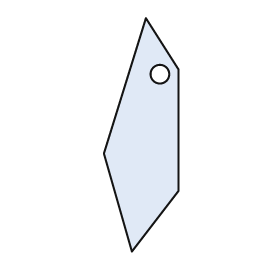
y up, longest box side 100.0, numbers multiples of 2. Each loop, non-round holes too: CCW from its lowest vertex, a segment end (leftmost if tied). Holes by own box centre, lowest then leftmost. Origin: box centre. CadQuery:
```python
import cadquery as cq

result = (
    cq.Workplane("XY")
    .moveTo(-4.0, -50.0)
    .lineTo(16.0, -24.0)
    .lineTo(16.0, 28.0)
    .lineTo(2.0, 50.0)
    .lineTo(-16.0, -8.0)
    .close()
    .moveTo(8.0, 26.0)
    .circle(4.0)
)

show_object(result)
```